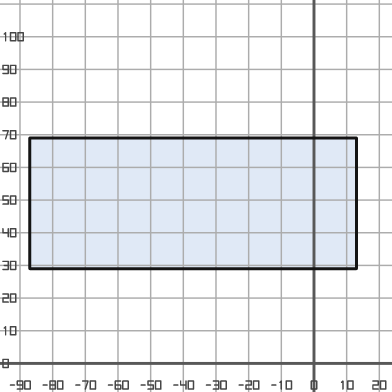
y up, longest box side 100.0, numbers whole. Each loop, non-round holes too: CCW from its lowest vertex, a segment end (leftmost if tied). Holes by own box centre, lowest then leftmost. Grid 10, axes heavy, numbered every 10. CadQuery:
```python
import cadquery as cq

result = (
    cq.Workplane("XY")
    .moveTo(-87.0, 29.0)
    .lineTo(13.0, 29.0)
    .lineTo(13.0, 69.0)
    .lineTo(-87.0, 69.0)
    .close()
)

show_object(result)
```